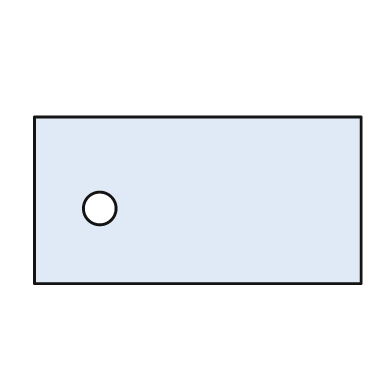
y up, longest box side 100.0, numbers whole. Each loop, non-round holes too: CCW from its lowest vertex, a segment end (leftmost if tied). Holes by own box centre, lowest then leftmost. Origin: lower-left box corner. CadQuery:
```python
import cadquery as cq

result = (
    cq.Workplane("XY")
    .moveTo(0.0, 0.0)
    .lineTo(100.0, 0.0)
    .lineTo(100.0, 51.0)
    .lineTo(0.0, 51.0)
    .close()
    .moveTo(20.0, 23.0)
    .circle(5.0)
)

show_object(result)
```